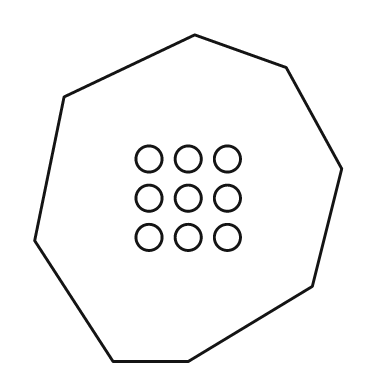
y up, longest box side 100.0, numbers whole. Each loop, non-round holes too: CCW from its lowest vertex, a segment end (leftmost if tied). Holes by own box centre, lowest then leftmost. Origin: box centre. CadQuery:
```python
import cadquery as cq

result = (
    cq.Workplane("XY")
    .moveTo(-23.0, -50.0)
    .lineTo(0.0, -50.0)
    .lineTo(38.0, -27.0)
    .lineTo(47.0, 9.0)
    .lineTo(30.0, 40.0)
    .lineTo(2.0, 50.0)
    .lineTo(-38.0, 31.0)
    .lineTo(-47.0, -13.0)
    .close()
    .moveTo(-12.0, -12.0)
    .circle(4.0)
    .moveTo(0.0, -12.0)
    .circle(4.0)
    .moveTo(12.0, -12.0)
    .circle(4.0)
    .moveTo(-12.0, 0.0)
    .circle(4.0)
    .moveTo(0.0, 0.0)
    .circle(4.0)
    .moveTo(12.0, 0.0)
    .circle(4.0)
    .moveTo(-12.0, 12.0)
    .circle(4.0)
    .moveTo(0.0, 12.0)
    .circle(4.0)
    .moveTo(12.0, 12.0)
    .circle(4.0)
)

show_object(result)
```